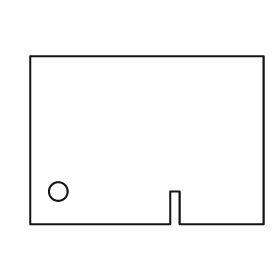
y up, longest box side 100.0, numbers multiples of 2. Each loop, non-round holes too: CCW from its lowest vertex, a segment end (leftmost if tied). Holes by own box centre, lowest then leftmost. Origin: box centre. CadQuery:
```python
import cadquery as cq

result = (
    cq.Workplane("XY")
    .moveTo(-50.0, -36.0)
    .lineTo(10.0, -36.0)
    .lineTo(10.0, -22.0)
    .lineTo(14.0, -22.0)
    .lineTo(14.0, -36.0)
    .lineTo(50.0, -36.0)
    .lineTo(50.0, 36.0)
    .lineTo(-50.0, 36.0)
    .close()
    .moveTo(-38.0, -22.0)
    .circle(4.0)
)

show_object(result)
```